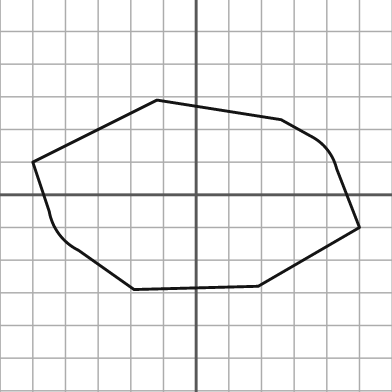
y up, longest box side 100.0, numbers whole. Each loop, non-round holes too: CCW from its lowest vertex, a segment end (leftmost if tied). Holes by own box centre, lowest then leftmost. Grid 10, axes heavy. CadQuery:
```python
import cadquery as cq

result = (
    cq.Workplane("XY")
    .moveTo(-19.0, -29.0)
    .lineTo(19.0, -28.0)
    .lineTo(50.0, -10.0)
    .lineTo(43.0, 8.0)
    .threePointArc((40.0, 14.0), (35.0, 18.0))
    .lineTo(26.0, 23.0)
    .lineTo(-12.0, 29.0)
    .lineTo(-50.0, 10.0)
    .lineTo(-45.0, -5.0)
    .threePointArc((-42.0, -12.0), (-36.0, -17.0))
    .close()
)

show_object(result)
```